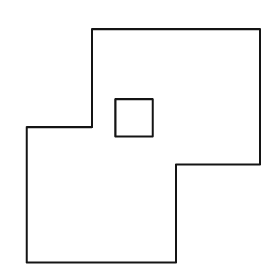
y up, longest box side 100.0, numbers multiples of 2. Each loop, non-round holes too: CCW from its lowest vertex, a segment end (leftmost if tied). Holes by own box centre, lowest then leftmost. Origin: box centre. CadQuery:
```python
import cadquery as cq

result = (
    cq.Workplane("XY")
    .moveTo(-50.0, -50.0)
    .lineTo(14.0, -50.0)
    .lineTo(14.0, -8.0)
    .lineTo(50.0, -8.0)
    .lineTo(50.0, 50.0)
    .lineTo(-22.0, 50.0)
    .lineTo(-22.0, 8.0)
    .lineTo(-50.0, 8.0)
    .close()
    .moveTo(-12.0, 4.0)
    .lineTo(4.0, 4.0)
    .lineTo(4.0, 20.0)
    .lineTo(-12.0, 20.0)
    .close()
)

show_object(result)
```